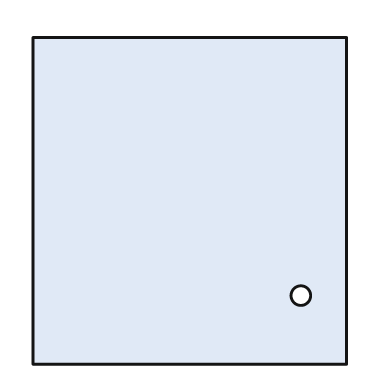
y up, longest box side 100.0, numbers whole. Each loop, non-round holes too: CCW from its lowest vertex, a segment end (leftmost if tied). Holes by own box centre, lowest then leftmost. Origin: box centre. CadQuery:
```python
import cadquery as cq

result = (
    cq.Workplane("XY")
    .moveTo(-48.0, -50.0)
    .lineTo(48.0, -50.0)
    .lineTo(48.0, 50.0)
    .lineTo(-48.0, 50.0)
    .close()
    .moveTo(34.0, -29.0)
    .circle(3.0)
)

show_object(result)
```